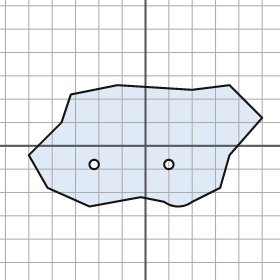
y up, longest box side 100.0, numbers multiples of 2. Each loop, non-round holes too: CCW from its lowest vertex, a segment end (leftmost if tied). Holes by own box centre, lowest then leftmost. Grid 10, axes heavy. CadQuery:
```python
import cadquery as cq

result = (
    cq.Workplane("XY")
    .moveTo(-24.0, -26.0)
    .lineTo(-2.0, -22.0)
    .lineTo(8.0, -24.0)
    .threePointArc((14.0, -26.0), (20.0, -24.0))
    .lineTo(32.0, -18.0)
    .lineTo(36.0, -4.0)
    .lineTo(50.0, 12.0)
    .lineTo(36.0, 26.0)
    .lineTo(20.0, 24.0)
    .lineTo(-12.0, 26.0)
    .lineTo(-32.0, 22.0)
    .lineTo(-36.0, 10.0)
    .lineTo(-50.0, -4.0)
    .lineTo(-42.0, -18.0)
    .close()
    .moveTo(-22.0, -8.0)
    .circle(2.0)
    .moveTo(10.0, -8.0)
    .circle(2.0)
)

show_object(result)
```